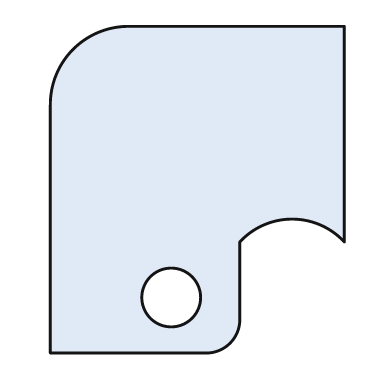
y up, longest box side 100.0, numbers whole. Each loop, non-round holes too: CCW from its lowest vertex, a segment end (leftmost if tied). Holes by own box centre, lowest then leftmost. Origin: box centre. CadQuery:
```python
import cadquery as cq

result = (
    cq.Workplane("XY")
    .moveTo(-45.0, -50.0)
    .lineTo(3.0, -50.0)
    .threePointArc((10.0, -47.0), (13.0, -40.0))
    .lineTo(13.0, -16.0)
    .threePointArc((29.0, -9.0), (45.0, -16.0))
    .lineTo(45.0, 50.0)
    .lineTo(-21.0, 50.0)
    .threePointArc((-38.0, 43.0), (-45.0, 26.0))
    .close()
    .moveTo(-8.0, -33.0)
    .circle(9.0)
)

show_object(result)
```